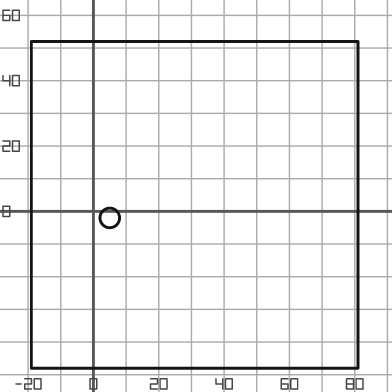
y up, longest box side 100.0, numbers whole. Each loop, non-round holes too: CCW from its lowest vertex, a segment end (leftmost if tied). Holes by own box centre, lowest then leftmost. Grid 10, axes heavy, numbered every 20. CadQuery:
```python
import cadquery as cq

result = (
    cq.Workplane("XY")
    .moveTo(-19.0, -48.0)
    .lineTo(81.0, -48.0)
    .lineTo(81.0, 52.0)
    .lineTo(-19.0, 52.0)
    .close()
    .moveTo(5.0, -2.0)
    .circle(3.0)
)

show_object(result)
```